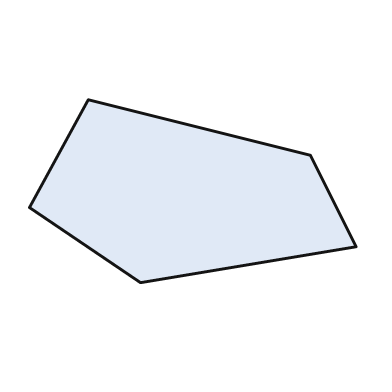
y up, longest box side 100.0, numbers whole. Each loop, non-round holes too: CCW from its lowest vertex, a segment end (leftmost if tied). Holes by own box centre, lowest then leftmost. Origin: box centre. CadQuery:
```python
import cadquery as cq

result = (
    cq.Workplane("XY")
    .moveTo(-16.0, -28.0)
    .lineTo(50.0, -17.0)
    .lineTo(36.0, 11.0)
    .lineTo(-32.0, 28.0)
    .lineTo(-50.0, -5.0)
    .close()
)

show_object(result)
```